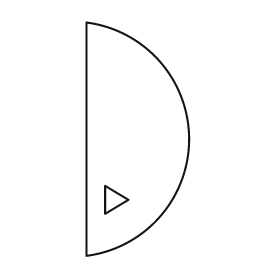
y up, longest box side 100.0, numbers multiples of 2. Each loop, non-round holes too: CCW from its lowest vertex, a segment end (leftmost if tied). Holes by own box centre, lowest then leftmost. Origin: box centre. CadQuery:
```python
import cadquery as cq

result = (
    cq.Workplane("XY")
    .moveTo(-22.0, -50.0)
    .threePointArc((22.0, 0.0), (-22.0, 50.0))
    .close()
    .moveTo(-14.0, -32.0)
    .lineTo(-4.0, -26.0)
    .lineTo(-14.0, -20.0)
    .close()
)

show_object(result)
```